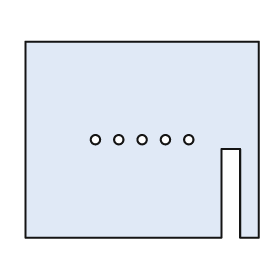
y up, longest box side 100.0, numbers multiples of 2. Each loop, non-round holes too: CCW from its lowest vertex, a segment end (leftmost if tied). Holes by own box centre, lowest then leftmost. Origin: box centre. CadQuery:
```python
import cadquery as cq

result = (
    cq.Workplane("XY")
    .moveTo(-50.0, -42.0)
    .lineTo(34.0, -42.0)
    .lineTo(34.0, -4.0)
    .lineTo(42.0, -4.0)
    .lineTo(42.0, -42.0)
    .lineTo(50.0, -42.0)
    .lineTo(50.0, 42.0)
    .lineTo(-50.0, 42.0)
    .close()
    .moveTo(-20.0, 0.0)
    .circle(2.0)
    .moveTo(-10.0, 0.0)
    .circle(2.0)
    .moveTo(0.0, 0.0)
    .circle(2.0)
    .moveTo(10.0, 0.0)
    .circle(2.0)
    .moveTo(20.0, 0.0)
    .circle(2.0)
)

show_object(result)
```